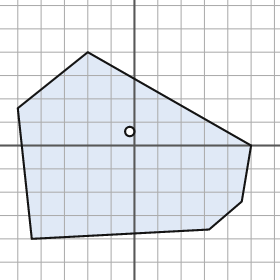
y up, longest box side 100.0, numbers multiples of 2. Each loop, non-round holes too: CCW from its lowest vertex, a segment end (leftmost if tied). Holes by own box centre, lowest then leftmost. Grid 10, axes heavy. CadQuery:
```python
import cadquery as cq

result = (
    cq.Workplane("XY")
    .moveTo(-44.0, -40.0)
    .lineTo(32.0, -36.0)
    .lineTo(46.0, -24.0)
    .lineTo(50.0, 0.0)
    .lineTo(-20.0, 40.0)
    .lineTo(-50.0, 16.0)
    .close()
    .moveTo(-2.0, 6.0)
    .circle(2.0)
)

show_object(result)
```